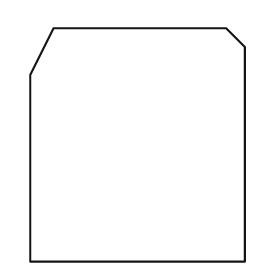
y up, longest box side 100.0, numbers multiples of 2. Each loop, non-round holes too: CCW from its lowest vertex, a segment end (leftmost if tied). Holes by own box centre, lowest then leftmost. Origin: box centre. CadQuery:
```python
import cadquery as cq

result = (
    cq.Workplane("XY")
    .moveTo(-46.0, -50.0)
    .lineTo(46.0, -50.0)
    .lineTo(46.0, 42.0)
    .lineTo(38.0, 50.0)
    .lineTo(-36.0, 50.0)
    .lineTo(-46.0, 30.0)
    .close()
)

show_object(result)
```